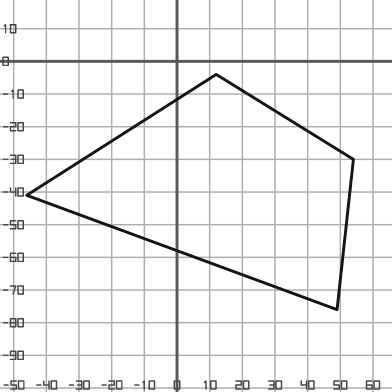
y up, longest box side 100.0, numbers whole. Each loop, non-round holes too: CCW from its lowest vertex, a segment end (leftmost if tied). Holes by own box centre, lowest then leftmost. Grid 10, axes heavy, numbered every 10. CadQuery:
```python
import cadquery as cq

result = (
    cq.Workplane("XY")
    .moveTo(49.0, -76.0)
    .lineTo(54.0, -30.0)
    .lineTo(12.0, -4.0)
    .lineTo(-46.0, -41.0)
    .close()
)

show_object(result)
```